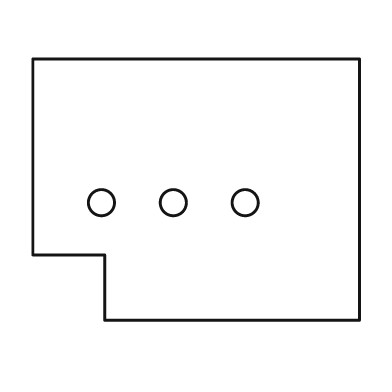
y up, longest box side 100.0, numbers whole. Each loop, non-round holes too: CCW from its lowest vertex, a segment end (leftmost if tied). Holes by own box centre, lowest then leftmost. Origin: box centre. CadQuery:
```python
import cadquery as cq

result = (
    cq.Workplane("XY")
    .moveTo(-28.0, -40.0)
    .lineTo(50.0, -40.0)
    .lineTo(50.0, 40.0)
    .lineTo(-50.0, 40.0)
    .lineTo(-50.0, -20.0)
    .lineTo(-28.0, -20.0)
    .close()
    .moveTo(-29.0, -4.0)
    .circle(4.0)
    .moveTo(-7.0, -4.0)
    .circle(4.0)
    .moveTo(15.0, -4.0)
    .circle(4.0)
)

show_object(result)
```